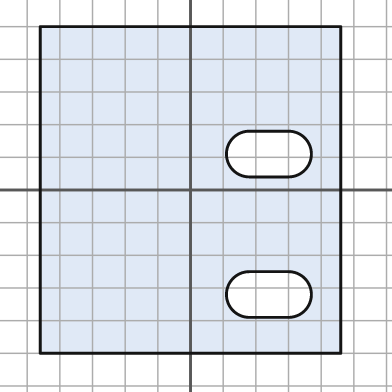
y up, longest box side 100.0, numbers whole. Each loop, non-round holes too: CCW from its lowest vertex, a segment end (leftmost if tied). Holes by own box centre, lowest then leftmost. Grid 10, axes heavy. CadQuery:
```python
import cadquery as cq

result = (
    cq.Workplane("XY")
    .moveTo(-46.0, -50.0)
    .lineTo(46.0, -50.0)
    .lineTo(46.0, 50.0)
    .lineTo(-46.0, 50.0)
    .close()
    .moveTo(18.0, -39.0)
    .lineTo(30.0, -39.0)
    .threePointArc((37.0, -32.0), (30.0, -25.0))
    .lineTo(18.0, -25.0)
    .threePointArc((11.0, -32.0), (18.0, -39.0))
    .close()
    .moveTo(18.0, 4.0)
    .lineTo(30.0, 4.0)
    .threePointArc((37.0, 11.0), (30.0, 18.0))
    .lineTo(18.0, 18.0)
    .threePointArc((11.0, 11.0), (18.0, 4.0))
    .close()
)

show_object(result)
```